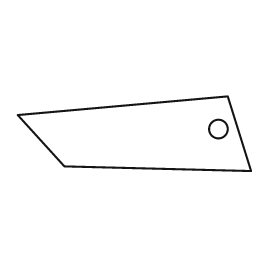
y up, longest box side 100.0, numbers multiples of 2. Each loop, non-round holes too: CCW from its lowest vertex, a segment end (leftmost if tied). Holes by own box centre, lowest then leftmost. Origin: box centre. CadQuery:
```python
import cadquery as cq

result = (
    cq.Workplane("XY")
    .moveTo(50.0, -16.0)
    .lineTo(40.0, 16.0)
    .lineTo(-50.0, 8.0)
    .lineTo(-30.0, -14.0)
    .close()
    .moveTo(36.0, 2.0)
    .circle(4.0)
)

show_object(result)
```